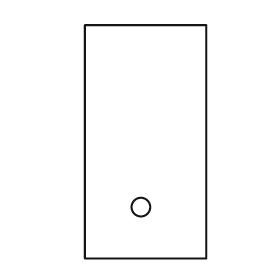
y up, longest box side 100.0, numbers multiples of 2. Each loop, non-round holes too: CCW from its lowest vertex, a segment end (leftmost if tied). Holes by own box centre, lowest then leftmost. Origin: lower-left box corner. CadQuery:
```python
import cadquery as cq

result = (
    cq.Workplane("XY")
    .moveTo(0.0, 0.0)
    .lineTo(52.0, 0.0)
    .lineTo(52.0, 100.0)
    .lineTo(0.0, 100.0)
    .close()
    .moveTo(24.0, 22.0)
    .circle(4.0)
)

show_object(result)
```